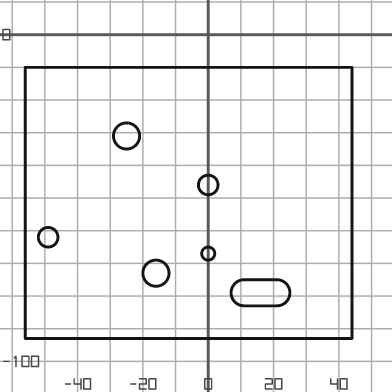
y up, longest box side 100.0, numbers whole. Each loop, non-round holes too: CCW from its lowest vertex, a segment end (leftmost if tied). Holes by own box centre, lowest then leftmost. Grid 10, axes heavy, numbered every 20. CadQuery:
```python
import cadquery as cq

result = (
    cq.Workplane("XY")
    .moveTo(-56.0, -93.0)
    .lineTo(44.0, -93.0)
    .lineTo(44.0, -10.0)
    .lineTo(-56.0, -10.0)
    .close()
    .moveTo(11.0, -83.0)
    .lineTo(21.0, -83.0)
    .threePointArc((25.0, -79.0), (21.0, -75.0))
    .lineTo(11.0, -75.0)
    .threePointArc((7.0, -79.0), (11.0, -83.0))
    .close()
    .moveTo(-16.0, -73.0)
    .circle(4.0)
    .moveTo(0.0, -67.0)
    .circle(2.0)
    .moveTo(-49.0, -62.0)
    .circle(3.0)
    .moveTo(0.0, -46.0)
    .circle(3.0)
    .moveTo(-25.0, -31.0)
    .circle(4.0)
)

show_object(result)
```